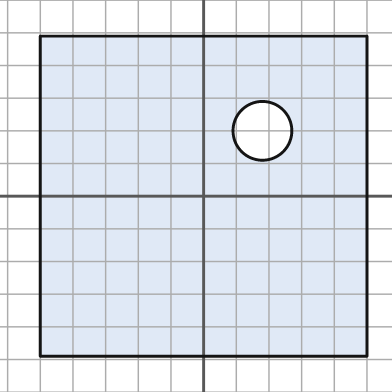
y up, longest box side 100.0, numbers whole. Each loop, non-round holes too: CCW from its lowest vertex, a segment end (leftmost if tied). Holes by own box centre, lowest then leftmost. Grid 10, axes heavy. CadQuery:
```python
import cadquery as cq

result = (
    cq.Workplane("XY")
    .moveTo(-50.0, -49.0)
    .lineTo(50.0, -49.0)
    .lineTo(50.0, 49.0)
    .lineTo(-50.0, 49.0)
    .close()
    .moveTo(18.0, 20.0)
    .circle(9.0)
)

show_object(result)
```